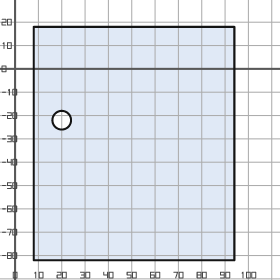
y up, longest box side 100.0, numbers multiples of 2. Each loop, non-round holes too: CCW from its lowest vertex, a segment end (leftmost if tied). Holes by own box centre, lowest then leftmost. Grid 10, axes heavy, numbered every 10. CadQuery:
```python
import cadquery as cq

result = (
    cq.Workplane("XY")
    .moveTo(8.0, -82.0)
    .lineTo(94.0, -82.0)
    .lineTo(94.0, 18.0)
    .lineTo(8.0, 18.0)
    .close()
    .moveTo(20.0, -22.0)
    .circle(4.0)
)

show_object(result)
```